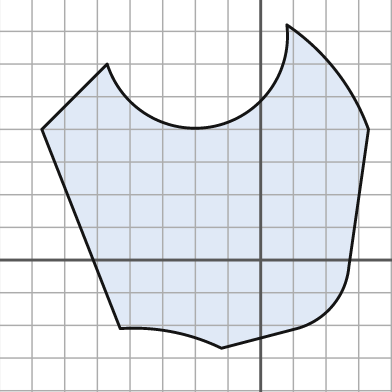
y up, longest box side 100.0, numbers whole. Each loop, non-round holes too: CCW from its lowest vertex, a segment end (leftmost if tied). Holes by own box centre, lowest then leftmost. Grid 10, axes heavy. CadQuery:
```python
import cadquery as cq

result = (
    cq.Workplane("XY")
    .moveTo(-12.0, -27.0)
    .lineTo(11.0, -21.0)
    .threePointArc((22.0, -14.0), (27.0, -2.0))
    .lineTo(33.0, 40.0)
    .threePointArc((23.0, 58.0), (8.0, 72.0))
    .threePointArc((-14.0, 41.0), (-47.0, 60.0))
    .lineTo(-67.0, 40.0)
    .lineTo(-43.0, -21.0)
    .threePointArc((-27.0, -22.0), (-12.0, -27.0))
    .close()
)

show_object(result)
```